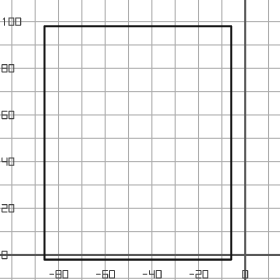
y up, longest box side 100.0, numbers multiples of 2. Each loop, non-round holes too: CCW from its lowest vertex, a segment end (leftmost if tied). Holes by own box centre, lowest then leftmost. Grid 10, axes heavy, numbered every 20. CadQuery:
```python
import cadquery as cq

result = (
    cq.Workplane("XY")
    .moveTo(-86.0, -2.0)
    .lineTo(-6.0, -2.0)
    .lineTo(-6.0, 98.0)
    .lineTo(-86.0, 98.0)
    .close()
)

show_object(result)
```